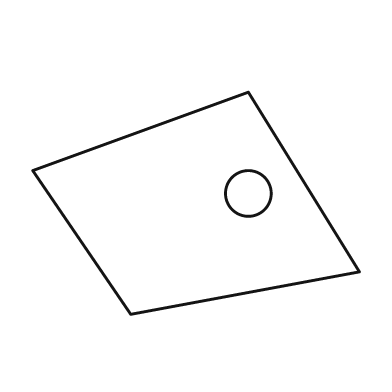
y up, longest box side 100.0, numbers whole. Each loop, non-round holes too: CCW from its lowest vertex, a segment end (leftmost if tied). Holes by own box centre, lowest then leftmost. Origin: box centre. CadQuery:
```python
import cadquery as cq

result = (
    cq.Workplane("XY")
    .moveTo(-20.0, -34.0)
    .lineTo(50.0, -21.0)
    .lineTo(16.0, 34.0)
    .lineTo(-50.0, 10.0)
    .close()
    .moveTo(16.0, 3.0)
    .circle(7.0)
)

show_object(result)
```